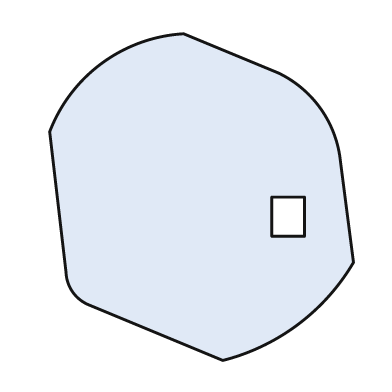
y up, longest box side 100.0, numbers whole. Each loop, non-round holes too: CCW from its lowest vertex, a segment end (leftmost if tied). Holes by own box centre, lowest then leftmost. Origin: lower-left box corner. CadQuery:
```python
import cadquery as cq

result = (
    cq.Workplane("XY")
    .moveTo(53.0, 0.0)
    .threePointArc((76.0, 11.0), (93.0, 30.0))
    .lineTo(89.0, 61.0)
    .threePointArc((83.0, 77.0), (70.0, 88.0))
    .lineTo(41.0, 100.0)
    .threePointArc((16.0, 91.0), (0.0, 70.0))
    .lineTo(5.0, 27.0)
    .threePointArc((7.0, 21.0), (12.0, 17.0))
    .close()
    .moveTo(68.0, 38.0)
    .lineTo(78.0, 38.0)
    .lineTo(78.0, 50.0)
    .lineTo(68.0, 50.0)
    .close()
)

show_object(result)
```